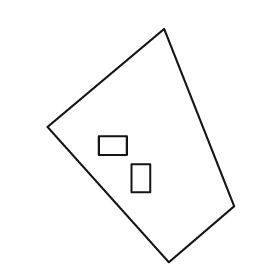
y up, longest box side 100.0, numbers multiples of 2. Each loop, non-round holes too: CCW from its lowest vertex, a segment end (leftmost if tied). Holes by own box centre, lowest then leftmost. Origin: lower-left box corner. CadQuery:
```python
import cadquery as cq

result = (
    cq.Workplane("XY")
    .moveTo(52.0, 0.0)
    .lineTo(80.0, 24.0)
    .lineTo(50.0, 100.0)
    .lineTo(0.0, 58.0)
    .close()
    .moveTo(36.0, 30.0)
    .lineTo(44.0, 30.0)
    .lineTo(44.0, 42.0)
    .lineTo(36.0, 42.0)
    .close()
    .moveTo(22.0, 46.0)
    .lineTo(34.0, 46.0)
    .lineTo(34.0, 54.0)
    .lineTo(22.0, 54.0)
    .close()
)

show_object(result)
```